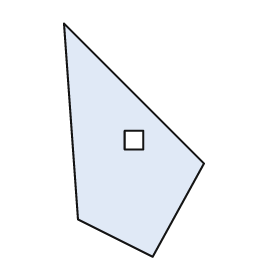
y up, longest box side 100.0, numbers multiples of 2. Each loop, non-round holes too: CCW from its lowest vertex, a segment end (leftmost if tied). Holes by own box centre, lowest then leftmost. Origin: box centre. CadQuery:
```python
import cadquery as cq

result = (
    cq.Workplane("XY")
    .moveTo(8.0, -50.0)
    .lineTo(30.0, -10.0)
    .lineTo(-30.0, 50.0)
    .lineTo(-24.0, -34.0)
    .close()
    .moveTo(-4.0, -4.0)
    .lineTo(4.0, -4.0)
    .lineTo(4.0, 4.0)
    .lineTo(-4.0, 4.0)
    .close()
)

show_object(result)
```